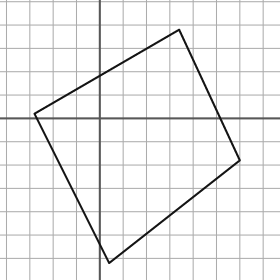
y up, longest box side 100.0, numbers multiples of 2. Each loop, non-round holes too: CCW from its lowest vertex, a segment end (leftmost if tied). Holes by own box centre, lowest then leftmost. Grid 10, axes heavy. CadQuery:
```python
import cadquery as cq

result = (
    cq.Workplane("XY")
    .moveTo(4.0, -62.0)
    .lineTo(60.0, -18.0)
    .lineTo(34.0, 38.0)
    .lineTo(-28.0, 2.0)
    .close()
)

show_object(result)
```